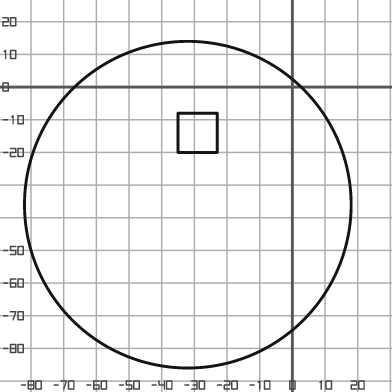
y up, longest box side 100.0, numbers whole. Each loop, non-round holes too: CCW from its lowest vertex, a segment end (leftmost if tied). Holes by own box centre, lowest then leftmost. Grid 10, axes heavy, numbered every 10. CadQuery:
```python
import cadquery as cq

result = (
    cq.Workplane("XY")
    .moveTo(-32.0, -36.0)
    .circle(50.0)
    .moveTo(-35.0, -20.0)
    .lineTo(-23.0, -20.0)
    .lineTo(-23.0, -8.0)
    .lineTo(-35.0, -8.0)
    .close()
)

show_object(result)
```